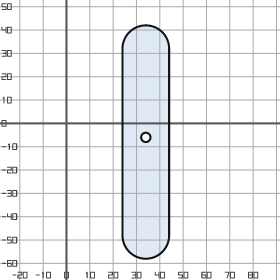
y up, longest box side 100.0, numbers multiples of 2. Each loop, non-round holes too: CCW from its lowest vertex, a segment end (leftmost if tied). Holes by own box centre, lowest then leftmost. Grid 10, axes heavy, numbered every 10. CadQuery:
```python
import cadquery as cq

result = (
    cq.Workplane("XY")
    .moveTo(24.0, -48.0)
    .threePointArc((34.0, -58.0), (44.0, -48.0))
    .lineTo(44.0, 32.0)
    .threePointArc((34.0, 42.0), (24.0, 32.0))
    .close()
    .moveTo(34.0, -6.0)
    .circle(2.0)
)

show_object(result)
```